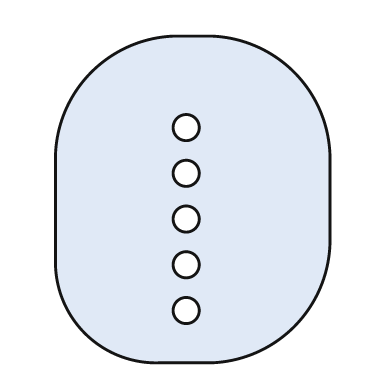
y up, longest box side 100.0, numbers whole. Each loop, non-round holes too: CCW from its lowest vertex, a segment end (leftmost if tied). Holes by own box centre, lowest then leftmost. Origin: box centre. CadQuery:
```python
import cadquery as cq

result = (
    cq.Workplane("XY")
    .moveTo(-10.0, -50.0)
    .lineTo(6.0, -50.0)
    .threePointArc((31.0, -39.0), (42.0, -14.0))
    .lineTo(42.0, 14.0)
    .threePointArc((31.0, 39.0), (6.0, 50.0))
    .lineTo(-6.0, 50.0)
    .threePointArc((-31.0, 39.0), (-42.0, 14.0))
    .lineTo(-42.0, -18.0)
    .threePointArc((-33.0, -41.0), (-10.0, -50.0))
    .close()
    .moveTo(-2.0, -34.0)
    .circle(4.0)
    .moveTo(-2.0, -20.0)
    .circle(4.0)
    .moveTo(-2.0, -6.0)
    .circle(4.0)
    .moveTo(-2.0, 8.0)
    .circle(4.0)
    .moveTo(-2.0, 22.0)
    .circle(4.0)
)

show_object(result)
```